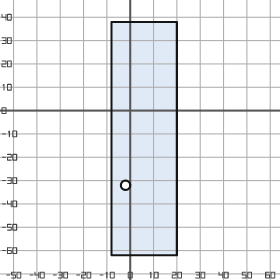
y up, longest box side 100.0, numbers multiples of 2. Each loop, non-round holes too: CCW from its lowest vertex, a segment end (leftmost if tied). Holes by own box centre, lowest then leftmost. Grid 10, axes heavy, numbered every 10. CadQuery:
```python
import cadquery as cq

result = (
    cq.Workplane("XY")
    .moveTo(-8.0, -62.0)
    .lineTo(20.0, -62.0)
    .lineTo(20.0, 38.0)
    .lineTo(-8.0, 38.0)
    .close()
    .moveTo(-2.0, -32.0)
    .circle(2.0)
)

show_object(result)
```